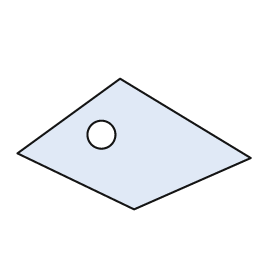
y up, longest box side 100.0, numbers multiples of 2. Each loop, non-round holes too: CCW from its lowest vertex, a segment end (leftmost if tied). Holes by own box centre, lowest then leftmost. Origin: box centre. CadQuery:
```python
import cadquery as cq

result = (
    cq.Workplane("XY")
    .moveTo(0.0, -28.0)
    .lineTo(50.0, -6.0)
    .lineTo(-6.0, 28.0)
    .lineTo(-50.0, -4.0)
    .close()
    .moveTo(-14.0, 4.0)
    .circle(6.0)
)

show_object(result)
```